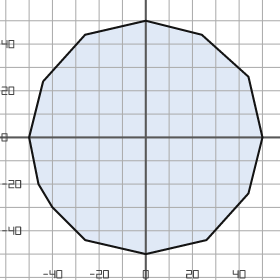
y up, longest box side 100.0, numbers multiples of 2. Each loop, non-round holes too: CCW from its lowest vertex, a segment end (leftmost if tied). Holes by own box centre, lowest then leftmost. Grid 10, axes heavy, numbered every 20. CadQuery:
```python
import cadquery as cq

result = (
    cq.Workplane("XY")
    .moveTo(0.0, -50.0)
    .lineTo(26.0, -44.0)
    .lineTo(44.0, -24.0)
    .lineTo(50.0, 0.0)
    .lineTo(44.0, 26.0)
    .lineTo(24.0, 44.0)
    .lineTo(0.0, 50.0)
    .lineTo(-26.0, 44.0)
    .lineTo(-44.0, 24.0)
    .lineTo(-50.0, 0.0)
    .lineTo(-46.0, -20.0)
    .lineTo(-40.0, -30.0)
    .lineTo(-26.0, -44.0)
    .close()
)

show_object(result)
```